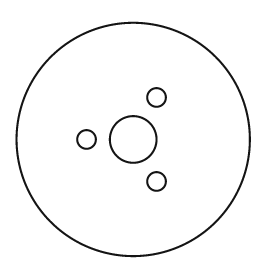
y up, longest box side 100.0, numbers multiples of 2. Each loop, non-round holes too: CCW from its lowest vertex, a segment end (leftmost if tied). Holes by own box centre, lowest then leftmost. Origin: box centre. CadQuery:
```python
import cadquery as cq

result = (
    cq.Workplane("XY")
    .moveTo(0.0, 0.0)
    .circle(50.0)
    .moveTo(10.0, -18.0)
    .circle(4.0)
    .moveTo(-20.0, 0.0)
    .circle(4.0)
    .moveTo(0.0, 0.0)
    .circle(10.0)
    .moveTo(10.0, 18.0)
    .circle(4.0)
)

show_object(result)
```